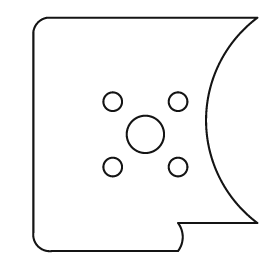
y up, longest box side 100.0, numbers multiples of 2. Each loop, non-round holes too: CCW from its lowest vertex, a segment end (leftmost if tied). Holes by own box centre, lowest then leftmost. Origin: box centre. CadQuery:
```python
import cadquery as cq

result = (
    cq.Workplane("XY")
    .moveTo(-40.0, -50.0)
    .lineTo(14.0, -50.0)
    .threePointArc((16.0, -44.0), (14.0, -38.0))
    .lineTo(48.0, -38.0)
    .threePointArc((26.0, 6.0), (48.0, 50.0))
    .lineTo(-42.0, 50.0)
    .threePointArc((-46.0, 48.0), (-48.0, 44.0))
    .lineTo(-48.0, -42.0)
    .threePointArc((-46.0, -48.0), (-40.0, -50.0))
    .close()
    .moveTo(-14.0, -14.0)
    .circle(4.0)
    .moveTo(14.0, -14.0)
    .circle(4.0)
    .moveTo(0.0, 0.0)
    .circle(8.0)
    .moveTo(-14.0, 14.0)
    .circle(4.0)
    .moveTo(14.0, 14.0)
    .circle(4.0)
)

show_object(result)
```